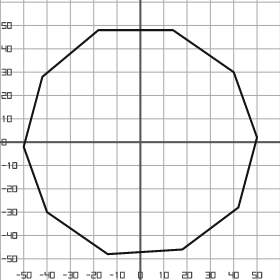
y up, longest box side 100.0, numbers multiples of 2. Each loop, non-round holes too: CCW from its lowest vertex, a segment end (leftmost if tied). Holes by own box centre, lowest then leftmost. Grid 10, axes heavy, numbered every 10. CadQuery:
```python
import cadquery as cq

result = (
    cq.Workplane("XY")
    .moveTo(-14.0, -48.0)
    .lineTo(18.0, -46.0)
    .lineTo(42.0, -28.0)
    .lineTo(50.0, 2.0)
    .lineTo(40.0, 30.0)
    .lineTo(14.0, 48.0)
    .lineTo(-18.0, 48.0)
    .lineTo(-42.0, 28.0)
    .lineTo(-50.0, -2.0)
    .lineTo(-40.0, -30.0)
    .close()
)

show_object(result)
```